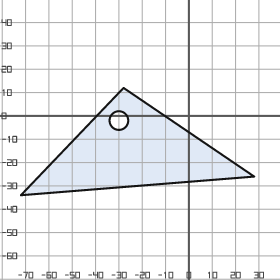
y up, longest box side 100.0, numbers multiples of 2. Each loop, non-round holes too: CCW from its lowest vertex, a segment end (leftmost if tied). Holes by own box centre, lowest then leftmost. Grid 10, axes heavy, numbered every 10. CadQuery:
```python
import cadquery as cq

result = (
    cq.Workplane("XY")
    .moveTo(-72.0, -34.0)
    .lineTo(28.0, -26.0)
    .lineTo(-28.0, 12.0)
    .close()
    .moveTo(-30.0, -2.0)
    .circle(4.0)
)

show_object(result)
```